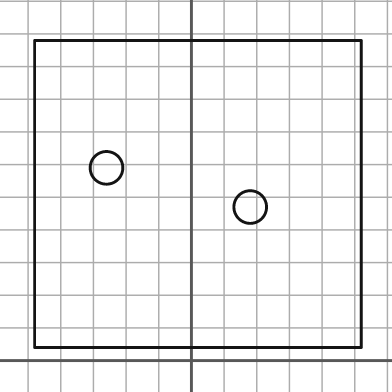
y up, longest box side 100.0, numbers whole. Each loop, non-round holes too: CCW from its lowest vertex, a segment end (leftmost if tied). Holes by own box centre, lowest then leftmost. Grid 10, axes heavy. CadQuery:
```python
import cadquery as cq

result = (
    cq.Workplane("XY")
    .moveTo(-48.0, 4.0)
    .lineTo(52.0, 4.0)
    .lineTo(52.0, 98.0)
    .lineTo(-48.0, 98.0)
    .close()
    .moveTo(18.0, 47.0)
    .circle(5.0)
    .moveTo(-26.0, 59.0)
    .circle(5.0)
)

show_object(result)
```